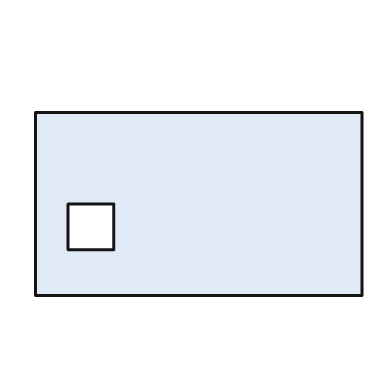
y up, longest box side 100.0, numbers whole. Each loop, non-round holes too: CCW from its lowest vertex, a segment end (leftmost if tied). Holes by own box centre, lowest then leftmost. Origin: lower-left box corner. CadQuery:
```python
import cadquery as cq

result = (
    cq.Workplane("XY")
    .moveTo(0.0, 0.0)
    .lineTo(100.0, 0.0)
    .lineTo(100.0, 56.0)
    .lineTo(0.0, 56.0)
    .close()
    .moveTo(10.0, 14.0)
    .lineTo(24.0, 14.0)
    .lineTo(24.0, 28.0)
    .lineTo(10.0, 28.0)
    .close()
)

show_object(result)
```